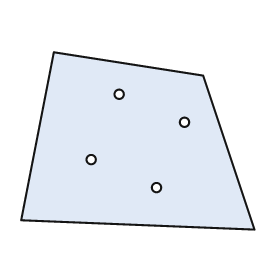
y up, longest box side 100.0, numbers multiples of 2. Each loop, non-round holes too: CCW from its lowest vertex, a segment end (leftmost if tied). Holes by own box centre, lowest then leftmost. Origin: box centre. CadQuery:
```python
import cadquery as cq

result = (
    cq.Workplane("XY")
    .moveTo(50.0, -38.0)
    .lineTo(28.0, 28.0)
    .lineTo(-36.0, 38.0)
    .lineTo(-50.0, -34.0)
    .close()
    .moveTo(8.0, -20.0)
    .circle(2.0)
    .moveTo(-20.0, -8.0)
    .circle(2.0)
    .moveTo(20.0, 8.0)
    .circle(2.0)
    .moveTo(-8.0, 20.0)
    .circle(2.0)
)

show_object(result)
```